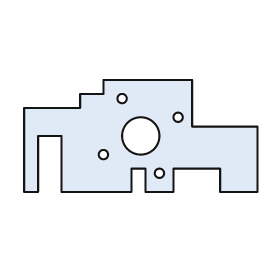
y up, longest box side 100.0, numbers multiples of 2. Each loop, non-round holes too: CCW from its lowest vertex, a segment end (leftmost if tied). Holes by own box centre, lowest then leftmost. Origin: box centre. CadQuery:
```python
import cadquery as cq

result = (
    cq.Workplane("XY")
    .moveTo(-50.0, -24.0)
    .lineTo(-44.0, -24.0)
    .lineTo(-44.0, 0.0)
    .lineTo(-34.0, 0.0)
    .lineTo(-34.0, -24.0)
    .lineTo(-4.0, -24.0)
    .lineTo(-4.0, -14.0)
    .lineTo(2.0, -14.0)
    .lineTo(2.0, -24.0)
    .lineTo(14.0, -24.0)
    .lineTo(14.0, -14.0)
    .lineTo(34.0, -14.0)
    .lineTo(34.0, -24.0)
    .lineTo(50.0, -24.0)
    .lineTo(50.0, 4.0)
    .lineTo(22.0, 4.0)
    .lineTo(22.0, 24.0)
    .lineTo(-16.0, 24.0)
    .lineTo(-16.0, 18.0)
    .lineTo(-26.0, 18.0)
    .lineTo(-26.0, 12.0)
    .lineTo(-50.0, 12.0)
    .close()
    .moveTo(8.0, -16.0)
    .circle(2.0)
    .moveTo(-16.0, -8.0)
    .circle(2.0)
    .moveTo(0.0, 0.0)
    .circle(8.0)
    .moveTo(16.0, 8.0)
    .circle(2.0)
    .moveTo(-8.0, 16.0)
    .circle(2.0)
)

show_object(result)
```